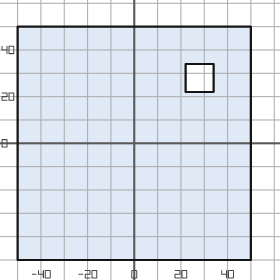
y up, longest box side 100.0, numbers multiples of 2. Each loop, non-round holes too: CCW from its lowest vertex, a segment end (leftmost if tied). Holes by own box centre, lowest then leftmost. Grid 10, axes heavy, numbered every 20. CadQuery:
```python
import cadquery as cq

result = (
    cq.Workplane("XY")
    .moveTo(-50.0, -50.0)
    .lineTo(50.0, -50.0)
    .lineTo(50.0, 50.0)
    .lineTo(-50.0, 50.0)
    .close()
    .moveTo(22.0, 22.0)
    .lineTo(34.0, 22.0)
    .lineTo(34.0, 34.0)
    .lineTo(22.0, 34.0)
    .close()
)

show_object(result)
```